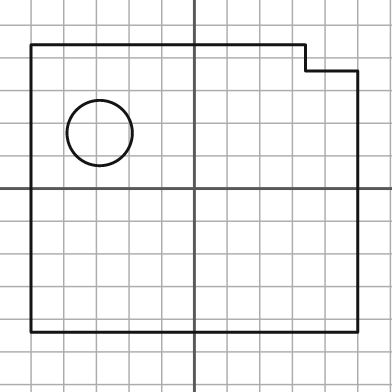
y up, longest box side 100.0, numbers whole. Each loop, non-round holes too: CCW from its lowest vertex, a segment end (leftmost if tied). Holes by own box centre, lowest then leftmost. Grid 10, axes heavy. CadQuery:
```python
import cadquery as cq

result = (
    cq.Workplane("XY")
    .moveTo(-50.0, -44.0)
    .lineTo(50.0, -44.0)
    .lineTo(50.0, 36.0)
    .lineTo(34.0, 36.0)
    .lineTo(34.0, 44.0)
    .lineTo(-50.0, 44.0)
    .close()
    .moveTo(-29.0, 17.0)
    .circle(10.0)
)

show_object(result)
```